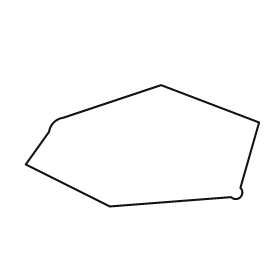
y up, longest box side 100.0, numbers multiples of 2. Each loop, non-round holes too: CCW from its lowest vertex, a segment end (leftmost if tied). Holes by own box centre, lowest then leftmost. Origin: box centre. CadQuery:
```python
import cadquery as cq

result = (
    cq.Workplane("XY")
    .moveTo(-14.0, -26.0)
    .lineTo(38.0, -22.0)
    .threePointArc((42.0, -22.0), (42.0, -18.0))
    .lineTo(50.0, 10.0)
    .lineTo(8.0, 26.0)
    .lineTo(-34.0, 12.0)
    .threePointArc((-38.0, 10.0), (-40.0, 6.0))
    .lineTo(-50.0, -8.0)
    .close()
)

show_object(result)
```